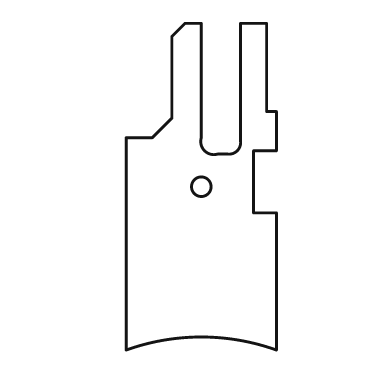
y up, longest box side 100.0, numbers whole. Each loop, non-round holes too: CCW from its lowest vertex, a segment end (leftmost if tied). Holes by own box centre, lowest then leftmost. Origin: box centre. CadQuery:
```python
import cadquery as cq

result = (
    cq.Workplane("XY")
    .moveTo(-23.0, -50.0)
    .threePointArc((0.0, -46.0), (23.0, -50.0))
    .lineTo(23.0, -8.0)
    .lineTo(16.0, -8.0)
    .lineTo(16.0, 11.0)
    .lineTo(23.0, 11.0)
    .lineTo(23.0, 23.0)
    .lineTo(20.0, 23.0)
    .lineTo(20.0, 50.0)
    .lineTo(12.0, 50.0)
    .lineTo(12.0, 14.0)
    .threePointArc((11.0, 11.0), (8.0, 10.0))
    .lineTo(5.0, 10.0)
    .threePointArc((1.0, 11.0), (0.0, 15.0))
    .lineTo(0.0, 50.0)
    .lineTo(-5.0, 50.0)
    .lineTo(-9.0, 46.0)
    .lineTo(-9.0, 21.0)
    .lineTo(-15.0, 15.0)
    .lineTo(-23.0, 15.0)
    .close()
    .moveTo(0.0, 0.0)
    .circle(3.0)
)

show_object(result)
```